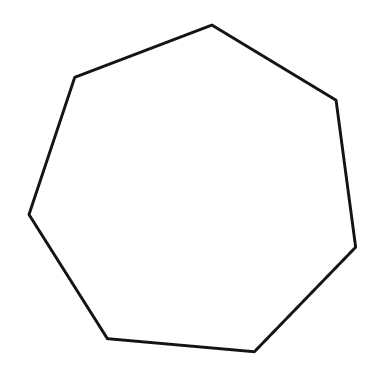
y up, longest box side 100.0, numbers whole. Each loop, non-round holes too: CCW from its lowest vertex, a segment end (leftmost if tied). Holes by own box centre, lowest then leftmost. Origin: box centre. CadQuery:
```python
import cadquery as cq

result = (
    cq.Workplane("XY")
    .moveTo(19.0, -50.0)
    .lineTo(50.0, -18.0)
    .lineTo(44.0, 27.0)
    .lineTo(6.0, 50.0)
    .lineTo(-36.0, 34.0)
    .lineTo(-50.0, -8.0)
    .lineTo(-26.0, -46.0)
    .close()
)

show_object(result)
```